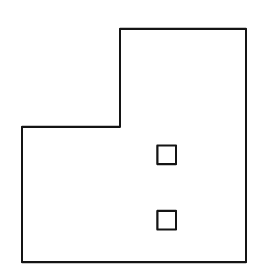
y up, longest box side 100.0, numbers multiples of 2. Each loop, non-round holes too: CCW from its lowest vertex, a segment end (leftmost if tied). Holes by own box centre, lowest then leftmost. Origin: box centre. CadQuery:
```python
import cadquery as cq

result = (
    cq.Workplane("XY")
    .moveTo(-48.0, -50.0)
    .lineTo(48.0, -50.0)
    .lineTo(48.0, 50.0)
    .lineTo(-6.0, 50.0)
    .lineTo(-6.0, 8.0)
    .lineTo(-48.0, 8.0)
    .close()
    .moveTo(10.0, -36.0)
    .lineTo(18.0, -36.0)
    .lineTo(18.0, -28.0)
    .lineTo(10.0, -28.0)
    .close()
    .moveTo(10.0, -8.0)
    .lineTo(18.0, -8.0)
    .lineTo(18.0, 0.0)
    .lineTo(10.0, 0.0)
    .close()
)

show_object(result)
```